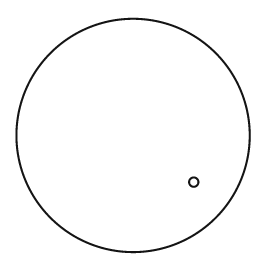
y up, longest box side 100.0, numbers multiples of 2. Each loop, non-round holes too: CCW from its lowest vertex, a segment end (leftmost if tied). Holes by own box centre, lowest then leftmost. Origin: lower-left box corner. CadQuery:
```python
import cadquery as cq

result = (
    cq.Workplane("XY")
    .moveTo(50.0, 50.0)
    .circle(50.0)
    .moveTo(76.0, 30.0)
    .circle(2.0)
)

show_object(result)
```